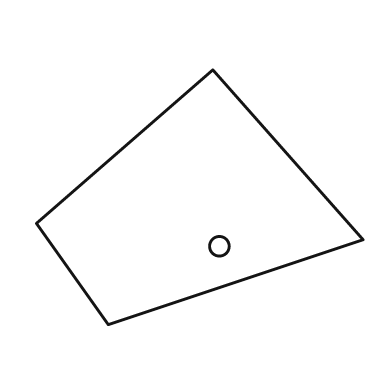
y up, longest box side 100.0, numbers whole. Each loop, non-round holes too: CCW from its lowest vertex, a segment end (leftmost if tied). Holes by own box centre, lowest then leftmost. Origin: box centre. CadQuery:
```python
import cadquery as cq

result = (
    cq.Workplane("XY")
    .moveTo(-28.0, -39.0)
    .lineTo(50.0, -13.0)
    .lineTo(4.0, 39.0)
    .lineTo(-50.0, -8.0)
    .close()
    .moveTo(6.0, -15.0)
    .circle(3.0)
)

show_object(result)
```